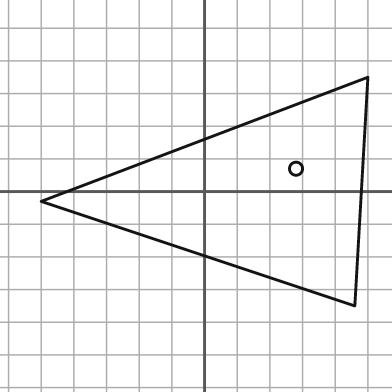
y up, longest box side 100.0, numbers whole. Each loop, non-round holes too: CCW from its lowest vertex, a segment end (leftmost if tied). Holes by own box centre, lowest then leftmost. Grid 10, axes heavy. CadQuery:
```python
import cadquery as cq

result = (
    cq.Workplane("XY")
    .moveTo(46.0, -35.0)
    .lineTo(50.0, 35.0)
    .lineTo(-50.0, -3.0)
    .close()
    .moveTo(28.0, 7.0)
    .circle(2.0)
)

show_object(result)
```